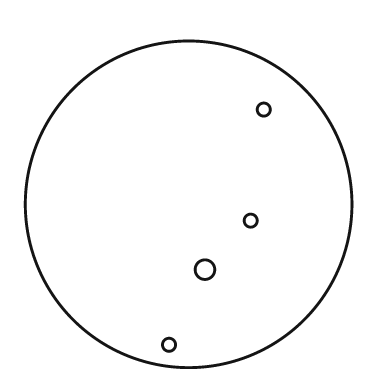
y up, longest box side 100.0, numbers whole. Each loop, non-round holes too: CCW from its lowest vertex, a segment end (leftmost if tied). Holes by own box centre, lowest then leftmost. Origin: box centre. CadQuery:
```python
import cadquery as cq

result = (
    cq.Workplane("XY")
    .moveTo(0.0, 0.0)
    .circle(50.0)
    .moveTo(-6.0, -43.0)
    .circle(2.0)
    .moveTo(5.0, -20.0)
    .circle(3.0)
    .moveTo(19.0, -5.0)
    .circle(2.0)
    .moveTo(23.0, 29.0)
    .circle(2.0)
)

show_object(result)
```